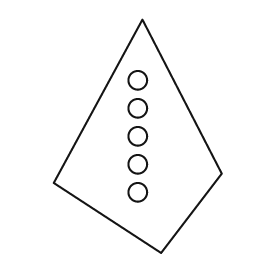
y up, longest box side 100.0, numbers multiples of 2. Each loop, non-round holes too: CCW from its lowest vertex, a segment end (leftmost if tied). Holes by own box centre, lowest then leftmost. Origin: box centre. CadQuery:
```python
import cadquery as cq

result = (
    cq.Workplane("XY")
    .moveTo(10.0, -50.0)
    .lineTo(36.0, -16.0)
    .lineTo(2.0, 50.0)
    .lineTo(-36.0, -20.0)
    .close()
    .moveTo(0.0, -24.0)
    .circle(4.0)
    .moveTo(0.0, -12.0)
    .circle(4.0)
    .moveTo(0.0, 0.0)
    .circle(4.0)
    .moveTo(0.0, 12.0)
    .circle(4.0)
    .moveTo(0.0, 24.0)
    .circle(4.0)
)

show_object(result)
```